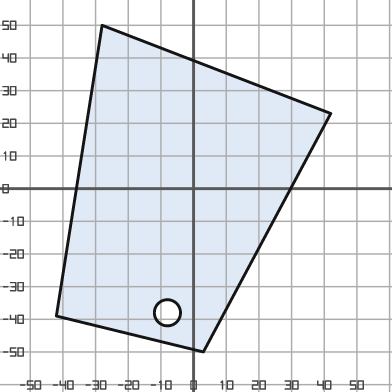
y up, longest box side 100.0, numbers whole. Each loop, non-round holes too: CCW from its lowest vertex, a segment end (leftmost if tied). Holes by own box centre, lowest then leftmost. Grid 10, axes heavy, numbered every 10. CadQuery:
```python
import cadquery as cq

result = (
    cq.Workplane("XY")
    .moveTo(3.0, -50.0)
    .lineTo(42.0, 23.0)
    .lineTo(-28.0, 50.0)
    .lineTo(-42.0, -39.0)
    .close()
    .moveTo(-8.0, -38.0)
    .circle(4.0)
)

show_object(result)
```